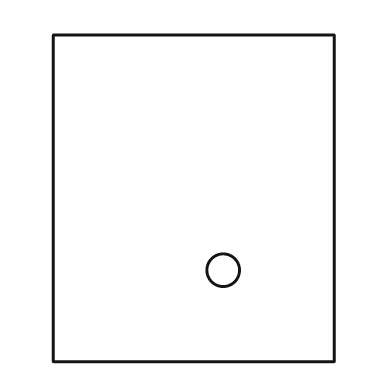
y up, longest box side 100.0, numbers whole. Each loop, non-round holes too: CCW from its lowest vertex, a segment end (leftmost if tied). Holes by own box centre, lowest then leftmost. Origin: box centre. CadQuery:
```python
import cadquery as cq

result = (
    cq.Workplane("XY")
    .moveTo(-43.0, -50.0)
    .lineTo(43.0, -50.0)
    .lineTo(43.0, 50.0)
    .lineTo(-43.0, 50.0)
    .close()
    .moveTo(9.0, -22.0)
    .circle(5.0)
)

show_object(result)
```